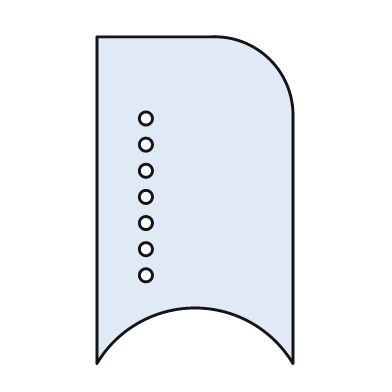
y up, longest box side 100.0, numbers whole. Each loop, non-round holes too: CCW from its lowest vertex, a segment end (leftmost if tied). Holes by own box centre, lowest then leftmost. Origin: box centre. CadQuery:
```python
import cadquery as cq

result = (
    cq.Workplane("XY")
    .moveTo(-30.0, -50.0)
    .threePointArc((0.0, -33.0), (30.0, -50.0))
    .lineTo(30.0, 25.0)
    .threePointArc((23.0, 43.0), (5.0, 50.0))
    .lineTo(-30.0, 50.0)
    .close()
    .moveTo(-15.0, -23.0)
    .circle(2.0)
    .moveTo(-15.0, -15.0)
    .circle(2.0)
    .moveTo(-15.0, -7.0)
    .circle(2.0)
    .moveTo(-15.0, 1.0)
    .circle(2.0)
    .moveTo(-15.0, 9.0)
    .circle(2.0)
    .moveTo(-15.0, 17.0)
    .circle(2.0)
    .moveTo(-15.0, 25.0)
    .circle(2.0)
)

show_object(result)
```